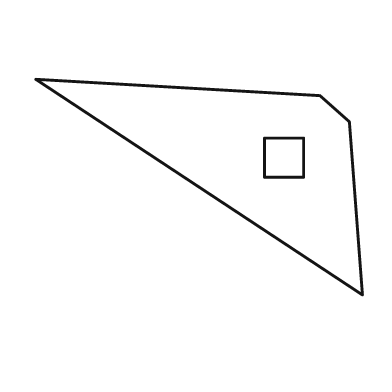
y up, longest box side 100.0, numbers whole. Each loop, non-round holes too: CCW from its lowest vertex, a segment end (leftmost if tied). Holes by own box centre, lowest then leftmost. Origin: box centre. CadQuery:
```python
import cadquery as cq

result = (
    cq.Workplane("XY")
    .moveTo(50.0, -33.0)
    .lineTo(46.0, 20.0)
    .lineTo(37.0, 28.0)
    .lineTo(-50.0, 33.0)
    .close()
    .moveTo(20.0, 3.0)
    .lineTo(32.0, 3.0)
    .lineTo(32.0, 15.0)
    .lineTo(20.0, 15.0)
    .close()
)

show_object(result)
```